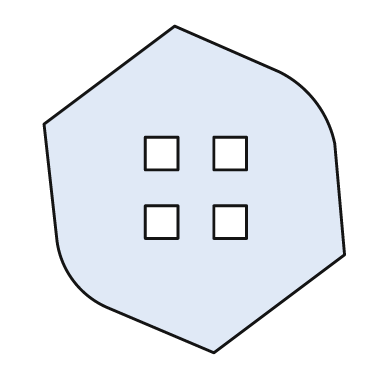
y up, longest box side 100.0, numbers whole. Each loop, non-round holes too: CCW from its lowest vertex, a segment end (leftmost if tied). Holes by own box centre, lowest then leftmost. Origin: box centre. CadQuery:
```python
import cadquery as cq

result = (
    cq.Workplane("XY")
    .moveTo(6.0, -50.0)
    .lineTo(46.0, -20.0)
    .lineTo(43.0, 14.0)
    .threePointArc((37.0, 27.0), (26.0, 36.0))
    .lineTo(-6.0, 50.0)
    .lineTo(-46.0, 20.0)
    .lineTo(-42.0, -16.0)
    .threePointArc((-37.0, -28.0), (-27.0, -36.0))
    .close()
    .moveTo(-15.0, -15.0)
    .lineTo(-5.0, -15.0)
    .lineTo(-5.0, -5.0)
    .lineTo(-15.0, -5.0)
    .close()
    .moveTo(6.0, -15.0)
    .lineTo(16.0, -15.0)
    .lineTo(16.0, -5.0)
    .lineTo(6.0, -5.0)
    .close()
    .moveTo(-15.0, 6.0)
    .lineTo(-5.0, 6.0)
    .lineTo(-5.0, 16.0)
    .lineTo(-15.0, 16.0)
    .close()
    .moveTo(6.0, 6.0)
    .lineTo(16.0, 6.0)
    .lineTo(16.0, 16.0)
    .lineTo(6.0, 16.0)
    .close()
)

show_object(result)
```